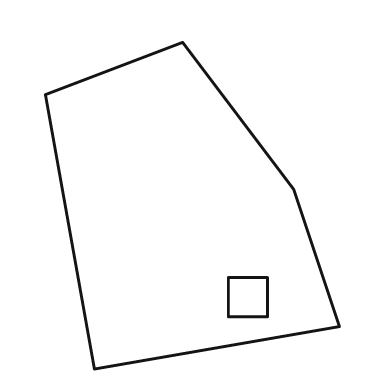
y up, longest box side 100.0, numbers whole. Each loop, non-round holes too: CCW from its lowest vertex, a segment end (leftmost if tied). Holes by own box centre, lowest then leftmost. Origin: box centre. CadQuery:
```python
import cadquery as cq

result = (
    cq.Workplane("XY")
    .moveTo(-30.0, -50.0)
    .lineTo(45.0, -37.0)
    .lineTo(31.0, 5.0)
    .lineTo(-3.0, 50.0)
    .lineTo(-45.0, 34.0)
    .close()
    .moveTo(11.0, -34.0)
    .lineTo(23.0, -34.0)
    .lineTo(23.0, -22.0)
    .lineTo(11.0, -22.0)
    .close()
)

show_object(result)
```